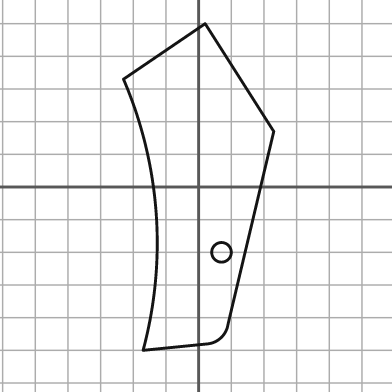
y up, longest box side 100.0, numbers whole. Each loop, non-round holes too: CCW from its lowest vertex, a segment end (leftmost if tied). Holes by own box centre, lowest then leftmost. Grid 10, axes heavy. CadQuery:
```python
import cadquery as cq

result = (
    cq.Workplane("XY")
    .moveTo(-17.0, -50.0)
    .lineTo(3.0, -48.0)
    .threePointArc((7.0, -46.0), (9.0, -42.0))
    .lineTo(23.0, 17.0)
    .lineTo(2.0, 50.0)
    .lineTo(-23.0, 33.0)
    .threePointArc((-13.0, -8.0), (-17.0, -50.0))
    .close()
    .moveTo(7.0, -20.0)
    .circle(3.0)
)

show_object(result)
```